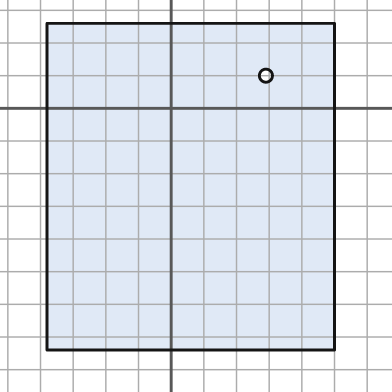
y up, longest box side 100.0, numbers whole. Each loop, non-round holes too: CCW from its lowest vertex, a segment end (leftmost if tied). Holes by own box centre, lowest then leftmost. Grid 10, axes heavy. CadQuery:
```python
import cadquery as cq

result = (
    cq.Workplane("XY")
    .moveTo(-38.0, -74.0)
    .lineTo(50.0, -74.0)
    .lineTo(50.0, 26.0)
    .lineTo(-38.0, 26.0)
    .close()
    .moveTo(29.0, 10.0)
    .circle(2.0)
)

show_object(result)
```